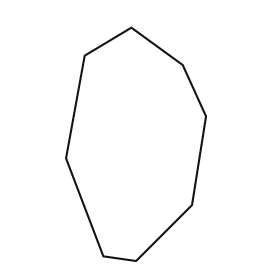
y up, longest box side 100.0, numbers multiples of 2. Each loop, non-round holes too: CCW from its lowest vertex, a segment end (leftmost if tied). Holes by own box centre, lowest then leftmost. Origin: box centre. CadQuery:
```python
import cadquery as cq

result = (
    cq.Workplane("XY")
    .moveTo(0.0, -50.0)
    .lineTo(24.0, -26.0)
    .lineTo(30.0, 12.0)
    .lineTo(20.0, 34.0)
    .lineTo(-2.0, 50.0)
    .lineTo(-22.0, 38.0)
    .lineTo(-30.0, -6.0)
    .lineTo(-14.0, -48.0)
    .close()
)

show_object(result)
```